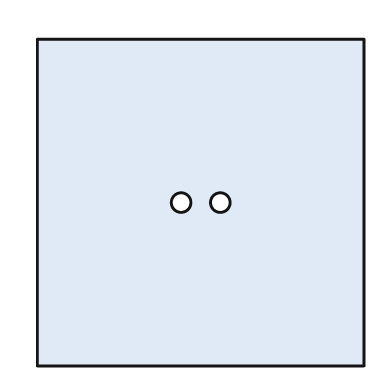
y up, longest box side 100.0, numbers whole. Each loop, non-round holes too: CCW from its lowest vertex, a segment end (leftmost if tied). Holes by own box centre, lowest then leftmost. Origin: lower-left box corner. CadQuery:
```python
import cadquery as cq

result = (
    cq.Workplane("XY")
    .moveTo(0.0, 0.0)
    .lineTo(100.0, 0.0)
    .lineTo(100.0, 100.0)
    .lineTo(0.0, 100.0)
    .close()
    .moveTo(44.0, 50.0)
    .circle(3.0)
    .moveTo(56.0, 50.0)
    .circle(3.0)
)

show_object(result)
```